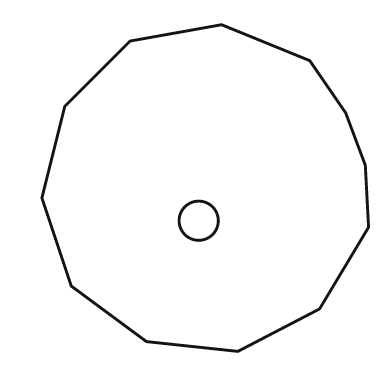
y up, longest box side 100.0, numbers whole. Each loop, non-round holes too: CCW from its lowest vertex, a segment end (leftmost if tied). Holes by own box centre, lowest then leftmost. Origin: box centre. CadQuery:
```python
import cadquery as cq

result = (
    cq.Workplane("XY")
    .moveTo(10.0, -50.0)
    .lineTo(35.0, -37.0)
    .lineTo(50.0, -12.0)
    .lineTo(49.0, 7.0)
    .lineTo(43.0, 23.0)
    .lineTo(32.0, 39.0)
    .lineTo(5.0, 50.0)
    .lineTo(-23.0, 45.0)
    .lineTo(-43.0, 25.0)
    .lineTo(-50.0, -3.0)
    .lineTo(-41.0, -30.0)
    .lineTo(-18.0, -47.0)
    .close()
    .moveTo(-2.0, -10.0)
    .circle(6.0)
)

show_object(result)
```